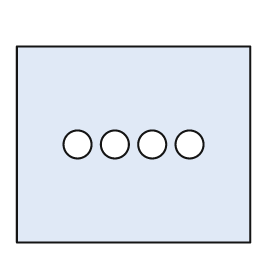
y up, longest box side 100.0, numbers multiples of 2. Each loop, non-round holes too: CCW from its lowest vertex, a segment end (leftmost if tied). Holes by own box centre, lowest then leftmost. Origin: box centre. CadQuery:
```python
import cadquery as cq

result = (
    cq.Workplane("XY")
    .moveTo(-50.0, -42.0)
    .lineTo(50.0, -42.0)
    .lineTo(50.0, 42.0)
    .lineTo(-50.0, 42.0)
    .close()
    .moveTo(-24.0, 0.0)
    .circle(6.0)
    .moveTo(-8.0, 0.0)
    .circle(6.0)
    .moveTo(8.0, 0.0)
    .circle(6.0)
    .moveTo(24.0, 0.0)
    .circle(6.0)
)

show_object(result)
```